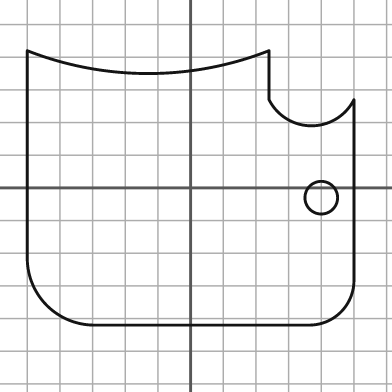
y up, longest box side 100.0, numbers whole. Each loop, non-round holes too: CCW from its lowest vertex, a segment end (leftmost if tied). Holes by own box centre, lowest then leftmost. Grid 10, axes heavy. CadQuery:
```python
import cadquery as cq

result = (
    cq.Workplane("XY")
    .moveTo(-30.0, -42.0)
    .lineTo(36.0, -42.0)
    .threePointArc((46.0, -38.0), (50.0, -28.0))
    .lineTo(50.0, 27.0)
    .threePointArc((37.0, 19.0), (24.0, 27.0))
    .lineTo(24.0, 42.0)
    .threePointArc((-13.0, 35.0), (-50.0, 42.0))
    .lineTo(-50.0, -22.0)
    .threePointArc((-44.0, -36.0), (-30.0, -42.0))
    .close()
    .moveTo(40.0, -3.0)
    .circle(5.0)
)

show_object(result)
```